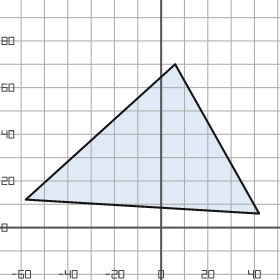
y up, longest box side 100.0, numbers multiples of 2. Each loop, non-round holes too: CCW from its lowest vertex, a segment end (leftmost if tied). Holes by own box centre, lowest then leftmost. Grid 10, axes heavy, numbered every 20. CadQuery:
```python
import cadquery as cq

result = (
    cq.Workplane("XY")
    .moveTo(42.0, 6.0)
    .lineTo(6.0, 70.0)
    .lineTo(-58.0, 12.0)
    .close()
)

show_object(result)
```